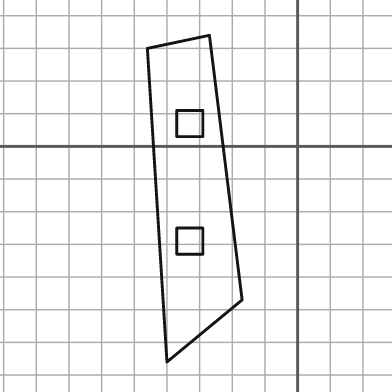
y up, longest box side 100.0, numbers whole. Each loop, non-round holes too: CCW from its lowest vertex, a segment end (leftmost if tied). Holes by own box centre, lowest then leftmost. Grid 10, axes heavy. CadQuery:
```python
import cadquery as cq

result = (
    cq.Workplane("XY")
    .moveTo(-40.0, -66.0)
    .lineTo(-17.0, -47.0)
    .lineTo(-27.0, 34.0)
    .lineTo(-46.0, 30.0)
    .close()
    .moveTo(-37.0, -33.0)
    .lineTo(-29.0, -33.0)
    .lineTo(-29.0, -25.0)
    .lineTo(-37.0, -25.0)
    .close()
    .moveTo(-37.0, 3.0)
    .lineTo(-29.0, 3.0)
    .lineTo(-29.0, 11.0)
    .lineTo(-37.0, 11.0)
    .close()
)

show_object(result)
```